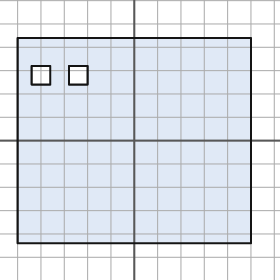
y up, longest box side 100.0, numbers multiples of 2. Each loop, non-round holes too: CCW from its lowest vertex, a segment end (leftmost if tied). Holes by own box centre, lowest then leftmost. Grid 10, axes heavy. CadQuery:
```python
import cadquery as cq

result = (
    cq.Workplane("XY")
    .moveTo(-50.0, -44.0)
    .lineTo(50.0, -44.0)
    .lineTo(50.0, 44.0)
    .lineTo(-50.0, 44.0)
    .close()
    .moveTo(-44.0, 24.0)
    .lineTo(-36.0, 24.0)
    .lineTo(-36.0, 32.0)
    .lineTo(-44.0, 32.0)
    .close()
    .moveTo(-28.0, 24.0)
    .lineTo(-20.0, 24.0)
    .lineTo(-20.0, 32.0)
    .lineTo(-28.0, 32.0)
    .close()
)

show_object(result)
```